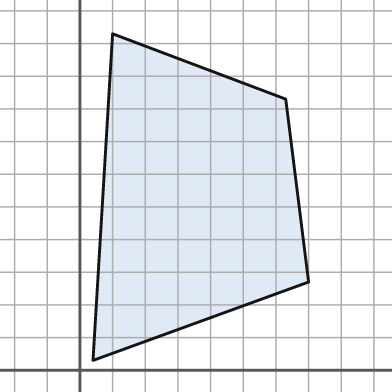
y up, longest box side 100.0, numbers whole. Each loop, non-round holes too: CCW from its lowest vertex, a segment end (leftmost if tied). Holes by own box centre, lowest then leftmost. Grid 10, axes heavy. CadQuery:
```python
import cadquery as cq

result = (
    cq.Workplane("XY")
    .moveTo(4.0, 3.0)
    .lineTo(70.0, 27.0)
    .lineTo(63.0, 83.0)
    .lineTo(10.0, 103.0)
    .close()
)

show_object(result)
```